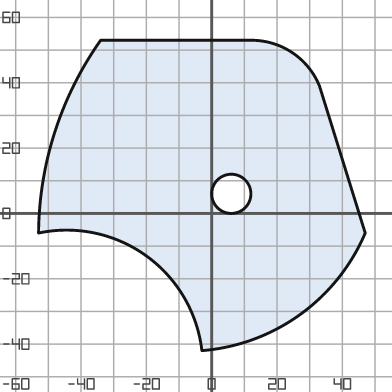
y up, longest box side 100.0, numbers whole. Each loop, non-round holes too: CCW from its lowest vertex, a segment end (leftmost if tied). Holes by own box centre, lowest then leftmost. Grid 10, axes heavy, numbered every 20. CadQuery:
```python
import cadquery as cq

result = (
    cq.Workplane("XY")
    .moveTo(-3.0, -42.0)
    .threePointArc((27.0, -31.0), (47.0, -6.0))
    .lineTo(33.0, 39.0)
    .threePointArc((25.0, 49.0), (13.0, 53.0))
    .lineTo(-34.0, 53.0)
    .threePointArc((-48.0, 25.0), (-53.0, -6.0))
    .threePointArc((-20.0, -13.0), (-3.0, -42.0))
    .close()
    .moveTo(6.0, 6.0)
    .circle(6.0)
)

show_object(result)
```